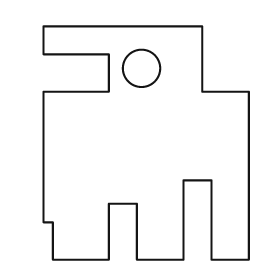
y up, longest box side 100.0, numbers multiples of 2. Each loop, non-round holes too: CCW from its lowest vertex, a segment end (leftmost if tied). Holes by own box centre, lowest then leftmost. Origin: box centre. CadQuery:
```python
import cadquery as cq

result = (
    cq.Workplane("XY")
    .moveTo(-40.0, -50.0)
    .lineTo(-16.0, -50.0)
    .lineTo(-16.0, -26.0)
    .lineTo(-4.0, -26.0)
    .lineTo(-4.0, -50.0)
    .lineTo(16.0, -50.0)
    .lineTo(16.0, -16.0)
    .lineTo(28.0, -16.0)
    .lineTo(28.0, -50.0)
    .lineTo(44.0, -50.0)
    .lineTo(44.0, 22.0)
    .lineTo(24.0, 22.0)
    .lineTo(24.0, 50.0)
    .lineTo(-44.0, 50.0)
    .lineTo(-44.0, 38.0)
    .lineTo(-16.0, 38.0)
    .lineTo(-16.0, 22.0)
    .lineTo(-44.0, 22.0)
    .lineTo(-44.0, -34.0)
    .lineTo(-40.0, -34.0)
    .close()
    .moveTo(-2.0, 32.0)
    .circle(8.0)
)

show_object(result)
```